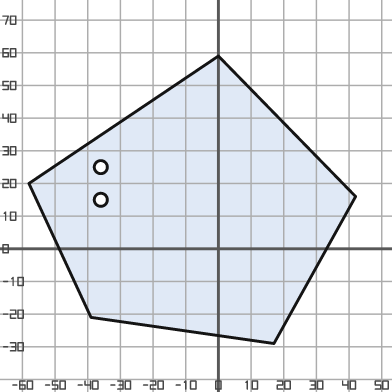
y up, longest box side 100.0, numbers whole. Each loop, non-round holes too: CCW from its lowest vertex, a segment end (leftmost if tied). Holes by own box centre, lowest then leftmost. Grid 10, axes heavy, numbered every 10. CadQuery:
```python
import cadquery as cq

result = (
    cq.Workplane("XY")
    .moveTo(17.0, -29.0)
    .lineTo(42.0, 16.0)
    .lineTo(0.0, 59.0)
    .lineTo(-58.0, 20.0)
    .lineTo(-39.0, -21.0)
    .close()
    .moveTo(-36.0, 15.0)
    .circle(2.0)
    .moveTo(-36.0, 25.0)
    .circle(2.0)
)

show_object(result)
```